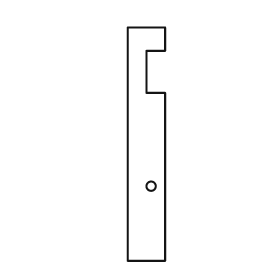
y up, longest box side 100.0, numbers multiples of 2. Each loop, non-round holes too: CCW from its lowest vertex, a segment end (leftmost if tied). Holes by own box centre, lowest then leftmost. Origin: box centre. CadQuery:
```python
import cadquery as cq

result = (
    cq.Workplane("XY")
    .moveTo(-8.0, -50.0)
    .lineTo(8.0, -50.0)
    .lineTo(8.0, 22.0)
    .lineTo(0.0, 22.0)
    .lineTo(0.0, 40.0)
    .lineTo(8.0, 40.0)
    .lineTo(8.0, 50.0)
    .lineTo(-8.0, 50.0)
    .close()
    .moveTo(2.0, -18.0)
    .circle(2.0)
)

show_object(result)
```